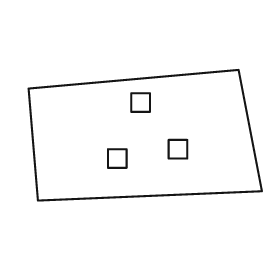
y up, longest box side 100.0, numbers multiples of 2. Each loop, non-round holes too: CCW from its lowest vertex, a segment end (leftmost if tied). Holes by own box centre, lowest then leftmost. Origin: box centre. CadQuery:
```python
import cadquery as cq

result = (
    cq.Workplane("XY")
    .moveTo(-46.0, -28.0)
    .lineTo(50.0, -24.0)
    .lineTo(40.0, 28.0)
    .lineTo(-50.0, 20.0)
    .close()
    .moveTo(-16.0, -14.0)
    .lineTo(-8.0, -14.0)
    .lineTo(-8.0, -6.0)
    .lineTo(-16.0, -6.0)
    .close()
    .moveTo(10.0, -10.0)
    .lineTo(18.0, -10.0)
    .lineTo(18.0, -2.0)
    .lineTo(10.0, -2.0)
    .close()
    .moveTo(-6.0, 10.0)
    .lineTo(2.0, 10.0)
    .lineTo(2.0, 18.0)
    .lineTo(-6.0, 18.0)
    .close()
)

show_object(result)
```